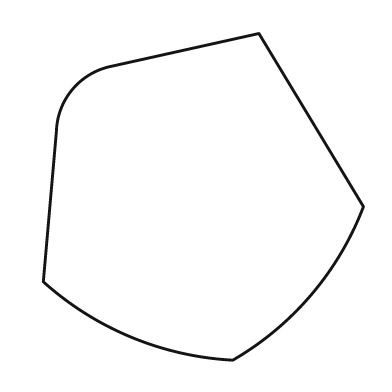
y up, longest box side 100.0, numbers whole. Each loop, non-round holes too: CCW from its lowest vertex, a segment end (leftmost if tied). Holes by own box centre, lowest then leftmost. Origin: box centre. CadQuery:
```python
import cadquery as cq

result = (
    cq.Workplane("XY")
    .moveTo(9.0, -50.0)
    .threePointArc((33.0, -30.0), (49.0, -3.0))
    .lineTo(17.0, 50.0)
    .lineTo(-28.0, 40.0)
    .threePointArc((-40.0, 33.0), (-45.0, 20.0))
    .lineTo(-49.0, -26.0)
    .threePointArc((-22.0, -43.0), (9.0, -50.0))
    .close()
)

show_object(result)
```